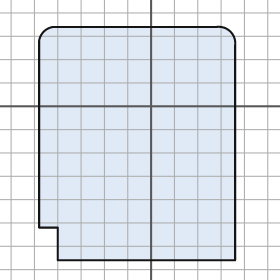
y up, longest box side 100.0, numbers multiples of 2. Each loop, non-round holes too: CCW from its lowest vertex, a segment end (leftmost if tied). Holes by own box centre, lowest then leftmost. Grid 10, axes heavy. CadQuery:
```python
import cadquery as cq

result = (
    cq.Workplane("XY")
    .moveTo(-40.0, -66.0)
    .lineTo(36.0, -66.0)
    .lineTo(36.0, 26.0)
    .threePointArc((34.0, 32.0), (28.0, 34.0))
    .lineTo(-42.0, 34.0)
    .threePointArc((-46.0, 32.0), (-48.0, 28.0))
    .lineTo(-48.0, -52.0)
    .lineTo(-40.0, -52.0)
    .close()
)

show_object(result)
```